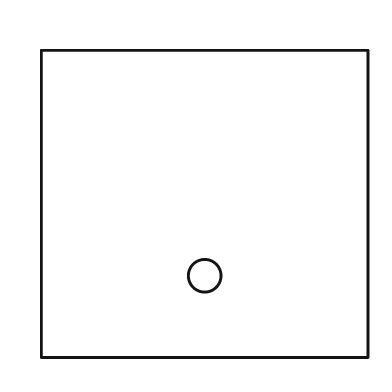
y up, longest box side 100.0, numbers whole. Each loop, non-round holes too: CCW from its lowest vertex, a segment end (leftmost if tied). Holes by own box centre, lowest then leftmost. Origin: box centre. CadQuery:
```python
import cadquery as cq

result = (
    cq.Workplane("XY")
    .moveTo(-50.0, -47.0)
    .lineTo(50.0, -47.0)
    .lineTo(50.0, 47.0)
    .lineTo(-50.0, 47.0)
    .close()
    .moveTo(0.0, -22.0)
    .circle(5.0)
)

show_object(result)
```